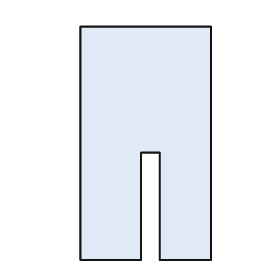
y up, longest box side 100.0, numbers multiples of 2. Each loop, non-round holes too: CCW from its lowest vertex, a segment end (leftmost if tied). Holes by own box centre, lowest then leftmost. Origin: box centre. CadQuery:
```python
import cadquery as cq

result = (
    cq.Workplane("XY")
    .moveTo(-28.0, -50.0)
    .lineTo(-2.0, -50.0)
    .lineTo(-2.0, -4.0)
    .lineTo(6.0, -4.0)
    .lineTo(6.0, -50.0)
    .lineTo(28.0, -50.0)
    .lineTo(28.0, 50.0)
    .lineTo(-28.0, 50.0)
    .close()
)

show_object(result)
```